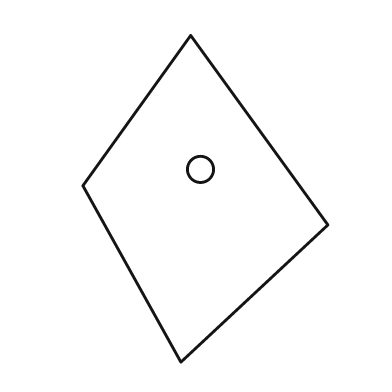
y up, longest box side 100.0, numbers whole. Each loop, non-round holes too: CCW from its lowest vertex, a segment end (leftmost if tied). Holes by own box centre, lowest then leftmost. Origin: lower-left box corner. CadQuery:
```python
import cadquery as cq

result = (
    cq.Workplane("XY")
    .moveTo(30.0, 0.0)
    .lineTo(75.0, 42.0)
    .lineTo(33.0, 100.0)
    .lineTo(0.0, 54.0)
    .close()
    .moveTo(36.0, 59.0)
    .circle(4.0)
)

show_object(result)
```